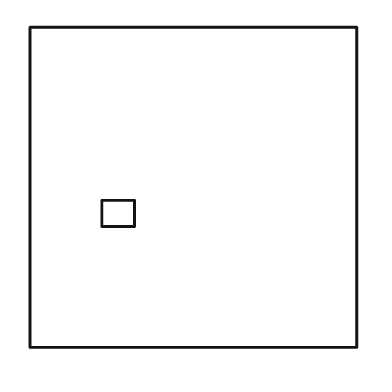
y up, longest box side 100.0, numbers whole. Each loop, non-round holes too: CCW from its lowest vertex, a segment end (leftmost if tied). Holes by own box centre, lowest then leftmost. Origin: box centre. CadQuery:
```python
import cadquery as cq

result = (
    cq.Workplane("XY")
    .moveTo(-50.0, -49.0)
    .lineTo(50.0, -49.0)
    .lineTo(50.0, 49.0)
    .lineTo(-50.0, 49.0)
    .close()
    .moveTo(-28.0, -12.0)
    .lineTo(-18.0, -12.0)
    .lineTo(-18.0, -4.0)
    .lineTo(-28.0, -4.0)
    .close()
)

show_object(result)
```